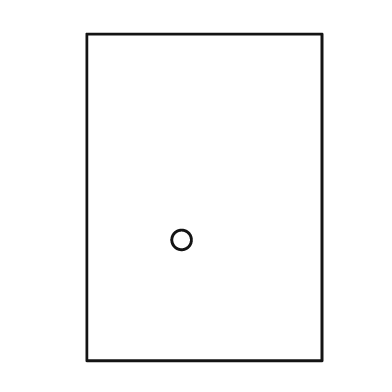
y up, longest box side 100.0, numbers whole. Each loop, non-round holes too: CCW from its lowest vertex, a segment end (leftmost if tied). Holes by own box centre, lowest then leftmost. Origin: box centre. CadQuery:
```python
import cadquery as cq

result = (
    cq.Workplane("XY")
    .moveTo(-36.0, -50.0)
    .lineTo(36.0, -50.0)
    .lineTo(36.0, 50.0)
    .lineTo(-36.0, 50.0)
    .close()
    .moveTo(-7.0, -13.0)
    .circle(3.0)
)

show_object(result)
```